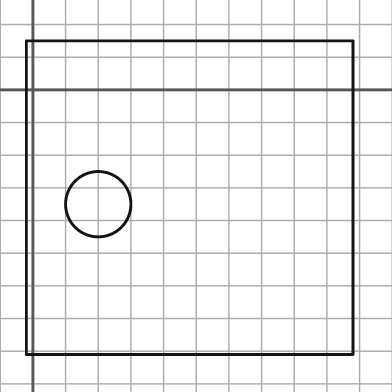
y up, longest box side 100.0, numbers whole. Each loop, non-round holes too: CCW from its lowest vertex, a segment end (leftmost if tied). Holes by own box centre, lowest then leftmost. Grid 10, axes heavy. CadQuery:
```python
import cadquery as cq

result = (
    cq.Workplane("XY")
    .moveTo(-2.0, -81.0)
    .lineTo(98.0, -81.0)
    .lineTo(98.0, 15.0)
    .lineTo(-2.0, 15.0)
    .close()
    .moveTo(20.0, -35.0)
    .circle(10.0)
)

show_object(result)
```